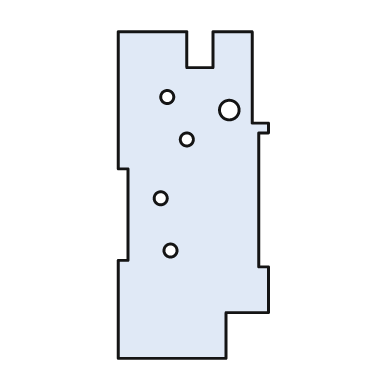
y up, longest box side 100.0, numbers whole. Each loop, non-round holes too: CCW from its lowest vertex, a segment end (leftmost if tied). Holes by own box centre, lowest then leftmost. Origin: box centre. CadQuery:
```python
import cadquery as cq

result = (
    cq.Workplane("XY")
    .moveTo(-23.0, -50.0)
    .lineTo(10.0, -50.0)
    .lineTo(10.0, -36.0)
    .lineTo(23.0, -36.0)
    .lineTo(23.0, -22.0)
    .lineTo(20.0, -22.0)
    .lineTo(20.0, 19.0)
    .lineTo(23.0, 19.0)
    .lineTo(23.0, 22.0)
    .lineTo(18.0, 22.0)
    .lineTo(18.0, 50.0)
    .lineTo(6.0, 50.0)
    .lineTo(6.0, 39.0)
    .lineTo(-2.0, 39.0)
    .lineTo(-2.0, 50.0)
    .lineTo(-23.0, 50.0)
    .lineTo(-23.0, 8.0)
    .lineTo(-20.0, 8.0)
    .lineTo(-20.0, -20.0)
    .lineTo(-23.0, -20.0)
    .close()
    .moveTo(-7.0, -17.0)
    .circle(2.0)
    .moveTo(-10.0, -1.0)
    .circle(2.0)
    .moveTo(-2.0, 17.0)
    .circle(2.0)
    .moveTo(11.0, 26.0)
    .circle(3.0)
    .moveTo(-8.0, 30.0)
    .circle(2.0)
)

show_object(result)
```